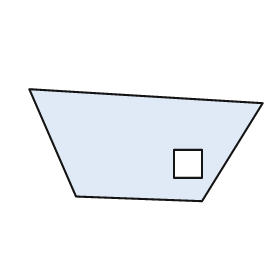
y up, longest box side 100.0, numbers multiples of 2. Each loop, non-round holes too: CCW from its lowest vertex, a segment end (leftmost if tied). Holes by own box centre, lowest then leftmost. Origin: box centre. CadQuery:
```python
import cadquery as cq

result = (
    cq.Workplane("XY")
    .moveTo(24.0, -24.0)
    .lineTo(50.0, 18.0)
    .lineTo(-50.0, 24.0)
    .lineTo(-30.0, -22.0)
    .close()
    .moveTo(12.0, -14.0)
    .lineTo(24.0, -14.0)
    .lineTo(24.0, -2.0)
    .lineTo(12.0, -2.0)
    .close()
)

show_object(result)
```